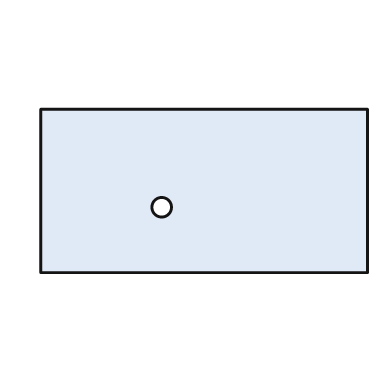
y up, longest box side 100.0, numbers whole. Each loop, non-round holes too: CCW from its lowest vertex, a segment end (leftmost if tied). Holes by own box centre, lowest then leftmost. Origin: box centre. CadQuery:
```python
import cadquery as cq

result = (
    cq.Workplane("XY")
    .moveTo(-50.0, -25.0)
    .lineTo(50.0, -25.0)
    .lineTo(50.0, 25.0)
    .lineTo(-50.0, 25.0)
    .close()
    .moveTo(-13.0, -5.0)
    .circle(3.0)
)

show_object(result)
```